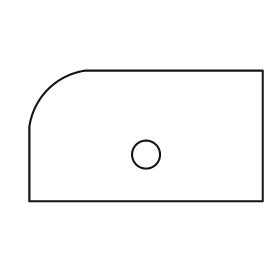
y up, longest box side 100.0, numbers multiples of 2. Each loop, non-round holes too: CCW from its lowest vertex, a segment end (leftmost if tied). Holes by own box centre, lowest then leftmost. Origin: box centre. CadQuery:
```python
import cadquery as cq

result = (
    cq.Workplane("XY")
    .moveTo(-50.0, -28.0)
    .lineTo(50.0, -28.0)
    .lineTo(50.0, 28.0)
    .lineTo(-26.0, 28.0)
    .threePointArc((-42.0, 20.0), (-50.0, 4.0))
    .close()
    .moveTo(0.0, -8.0)
    .circle(6.0)
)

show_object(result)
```